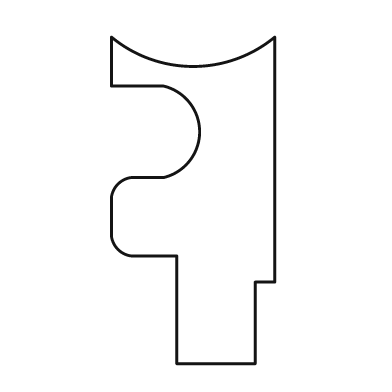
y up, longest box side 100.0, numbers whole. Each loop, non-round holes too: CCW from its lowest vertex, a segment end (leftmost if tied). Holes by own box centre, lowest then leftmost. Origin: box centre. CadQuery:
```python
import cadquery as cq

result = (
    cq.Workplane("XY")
    .moveTo(-5.0, -50.0)
    .lineTo(19.0, -50.0)
    .lineTo(19.0, -25.0)
    .lineTo(25.0, -25.0)
    .lineTo(25.0, 50.0)
    .threePointArc((0.0, 41.0), (-25.0, 50.0))
    .lineTo(-25.0, 35.0)
    .lineTo(-9.0, 35.0)
    .threePointArc((2.0, 21.0), (-9.0, 7.0))
    .lineTo(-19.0, 7.0)
    .threePointArc((-23.0, 5.0), (-25.0, 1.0))
    .lineTo(-25.0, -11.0)
    .threePointArc((-23.0, -15.0), (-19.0, -17.0))
    .lineTo(-5.0, -17.0)
    .close()
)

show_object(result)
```